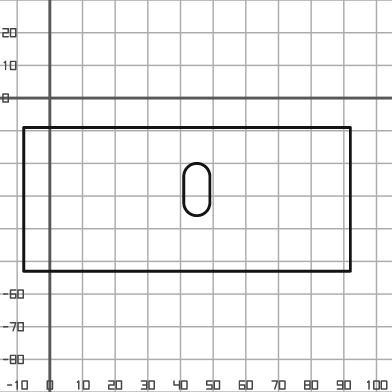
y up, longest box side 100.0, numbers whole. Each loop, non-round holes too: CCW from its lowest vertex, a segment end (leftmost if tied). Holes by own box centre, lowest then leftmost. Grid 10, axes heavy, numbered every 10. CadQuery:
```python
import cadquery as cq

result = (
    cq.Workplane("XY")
    .moveTo(-8.0, -53.0)
    .lineTo(92.0, -53.0)
    .lineTo(92.0, -9.0)
    .lineTo(-8.0, -9.0)
    .close()
    .moveTo(41.0, -32.0)
    .threePointArc((45.0, -36.0), (49.0, -32.0))
    .lineTo(49.0, -24.0)
    .threePointArc((45.0, -20.0), (41.0, -24.0))
    .close()
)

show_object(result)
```